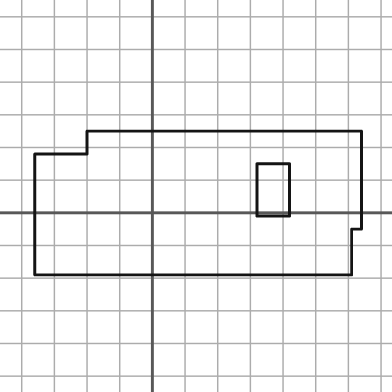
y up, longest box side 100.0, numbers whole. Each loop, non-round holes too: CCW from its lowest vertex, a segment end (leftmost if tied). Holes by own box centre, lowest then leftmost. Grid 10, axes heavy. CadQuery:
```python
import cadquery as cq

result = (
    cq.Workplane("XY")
    .moveTo(-36.0, -19.0)
    .lineTo(61.0, -19.0)
    .lineTo(61.0, -5.0)
    .lineTo(64.0, -5.0)
    .lineTo(64.0, 25.0)
    .lineTo(-20.0, 25.0)
    .lineTo(-20.0, 18.0)
    .lineTo(-36.0, 18.0)
    .close()
    .moveTo(32.0, -1.0)
    .lineTo(42.0, -1.0)
    .lineTo(42.0, 15.0)
    .lineTo(32.0, 15.0)
    .close()
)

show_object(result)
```